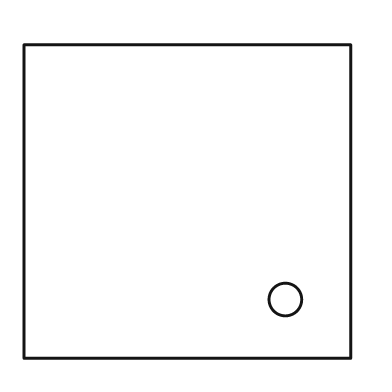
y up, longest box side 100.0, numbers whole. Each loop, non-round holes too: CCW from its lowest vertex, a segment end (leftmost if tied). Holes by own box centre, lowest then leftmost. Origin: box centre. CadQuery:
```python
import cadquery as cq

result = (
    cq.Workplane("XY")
    .moveTo(-50.0, -48.0)
    .lineTo(50.0, -48.0)
    .lineTo(50.0, 48.0)
    .lineTo(-50.0, 48.0)
    .close()
    .moveTo(30.0, -30.0)
    .circle(5.0)
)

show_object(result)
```